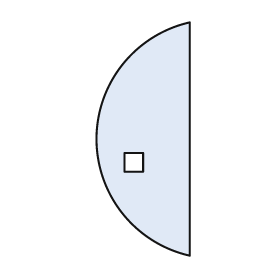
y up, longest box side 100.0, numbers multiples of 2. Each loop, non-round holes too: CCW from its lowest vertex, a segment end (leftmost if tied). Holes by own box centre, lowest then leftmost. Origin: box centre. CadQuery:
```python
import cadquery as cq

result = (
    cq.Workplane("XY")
    .moveTo(20.0, -50.0)
    .lineTo(20.0, 50.0)
    .threePointArc((-20.0, 0.0), (20.0, -50.0))
    .close()
    .moveTo(-8.0, -14.0)
    .lineTo(0.0, -14.0)
    .lineTo(0.0, -6.0)
    .lineTo(-8.0, -6.0)
    .close()
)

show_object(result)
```